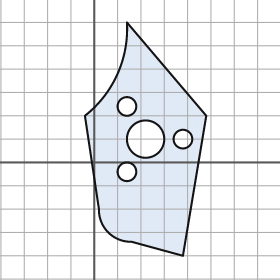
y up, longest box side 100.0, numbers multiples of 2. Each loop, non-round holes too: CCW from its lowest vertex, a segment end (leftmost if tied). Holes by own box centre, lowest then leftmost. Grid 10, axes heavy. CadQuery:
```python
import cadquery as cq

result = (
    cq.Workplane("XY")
    .moveTo(38.0, -40.0)
    .lineTo(48.0, 20.0)
    .lineTo(14.0, 60.0)
    .threePointArc((10.0, 38.0), (-4.0, 20.0))
    .lineTo(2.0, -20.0)
    .threePointArc((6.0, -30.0), (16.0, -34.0))
    .close()
    .moveTo(14.0, -4.0)
    .circle(4.0)
    .moveTo(22.0, 10.0)
    .circle(8.0)
    .moveTo(38.0, 10.0)
    .circle(4.0)
    .moveTo(14.0, 24.0)
    .circle(4.0)
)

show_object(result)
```